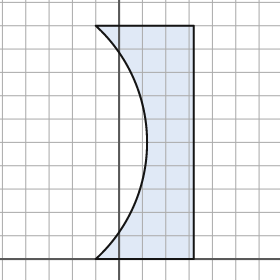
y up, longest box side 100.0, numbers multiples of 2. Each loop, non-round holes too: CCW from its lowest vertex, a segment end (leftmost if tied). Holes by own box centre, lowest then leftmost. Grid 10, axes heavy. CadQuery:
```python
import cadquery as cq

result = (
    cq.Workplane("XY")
    .moveTo(-10.0, 0.0)
    .lineTo(32.0, 0.0)
    .lineTo(32.0, 100.0)
    .lineTo(-10.0, 100.0)
    .threePointArc((12.0, 50.0), (-10.0, 0.0))
    .close()
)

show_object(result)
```